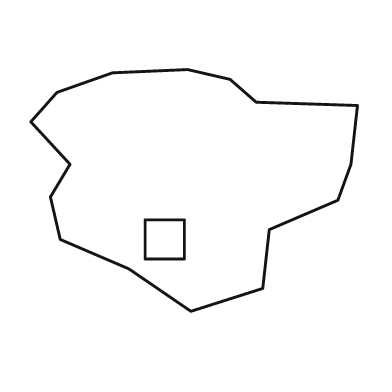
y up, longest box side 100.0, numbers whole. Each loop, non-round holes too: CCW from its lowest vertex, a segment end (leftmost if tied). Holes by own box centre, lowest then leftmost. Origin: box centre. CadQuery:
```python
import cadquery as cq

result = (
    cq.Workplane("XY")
    .moveTo(-1.0, -37.0)
    .lineTo(21.0, -30.0)
    .lineTo(23.0, -12.0)
    .lineTo(44.0, -3.0)
    .lineTo(48.0, 8.0)
    .lineTo(50.0, 26.0)
    .lineTo(19.0, 27.0)
    .lineTo(11.0, 34.0)
    .lineTo(-2.0, 37.0)
    .lineTo(-25.0, 36.0)
    .lineTo(-42.0, 30.0)
    .lineTo(-50.0, 21.0)
    .lineTo(-38.0, 8.0)
    .lineTo(-44.0, -2.0)
    .lineTo(-41.0, -15.0)
    .lineTo(-20.0, -24.0)
    .close()
    .moveTo(-15.0, -21.0)
    .lineTo(-3.0, -21.0)
    .lineTo(-3.0, -9.0)
    .lineTo(-15.0, -9.0)
    .close()
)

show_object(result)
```